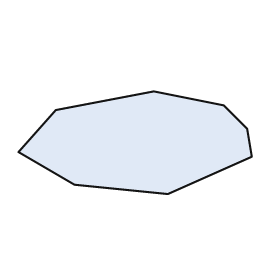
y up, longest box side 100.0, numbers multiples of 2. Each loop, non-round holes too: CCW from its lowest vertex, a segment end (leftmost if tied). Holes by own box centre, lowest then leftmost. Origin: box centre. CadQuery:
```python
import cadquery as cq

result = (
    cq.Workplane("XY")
    .moveTo(14.0, -22.0)
    .lineTo(50.0, -6.0)
    .lineTo(48.0, 6.0)
    .lineTo(38.0, 16.0)
    .lineTo(8.0, 22.0)
    .lineTo(-34.0, 14.0)
    .lineTo(-50.0, -4.0)
    .lineTo(-26.0, -18.0)
    .close()
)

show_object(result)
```